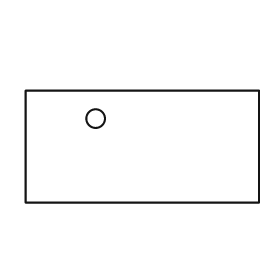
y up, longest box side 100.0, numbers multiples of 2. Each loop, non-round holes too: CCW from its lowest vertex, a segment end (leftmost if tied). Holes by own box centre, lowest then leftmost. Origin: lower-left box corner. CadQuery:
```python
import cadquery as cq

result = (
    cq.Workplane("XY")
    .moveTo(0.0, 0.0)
    .lineTo(100.0, 0.0)
    .lineTo(100.0, 48.0)
    .lineTo(0.0, 48.0)
    .close()
    .moveTo(30.0, 36.0)
    .circle(4.0)
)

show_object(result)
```